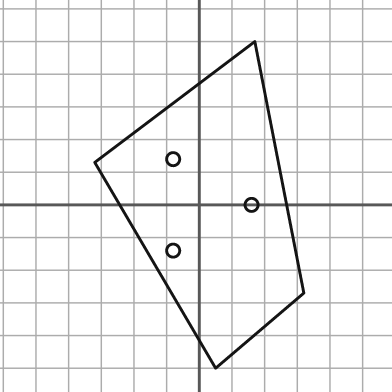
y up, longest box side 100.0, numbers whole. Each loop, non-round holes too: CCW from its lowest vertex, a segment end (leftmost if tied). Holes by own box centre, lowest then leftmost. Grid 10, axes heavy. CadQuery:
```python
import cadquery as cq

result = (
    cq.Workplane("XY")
    .moveTo(5.0, -50.0)
    .lineTo(32.0, -27.0)
    .lineTo(17.0, 50.0)
    .lineTo(-32.0, 13.0)
    .close()
    .moveTo(-8.0, -14.0)
    .circle(2.0)
    .moveTo(16.0, 0.0)
    .circle(2.0)
    .moveTo(-8.0, 14.0)
    .circle(2.0)
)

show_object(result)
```